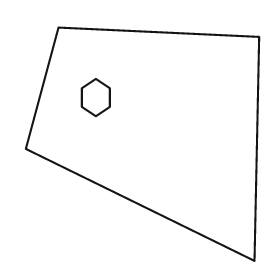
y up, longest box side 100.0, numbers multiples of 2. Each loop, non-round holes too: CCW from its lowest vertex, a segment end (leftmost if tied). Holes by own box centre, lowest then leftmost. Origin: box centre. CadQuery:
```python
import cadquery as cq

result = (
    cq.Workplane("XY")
    .moveTo(48.0, -50.0)
    .lineTo(50.0, 46.0)
    .lineTo(-36.0, 50.0)
    .lineTo(-50.0, -2.0)
    .close()
    .moveTo(-20.0, 12.0)
    .lineTo(-14.0, 16.0)
    .lineTo(-14.0, 24.0)
    .lineTo(-20.0, 28.0)
    .lineTo(-26.0, 24.0)
    .lineTo(-26.0, 16.0)
    .close()
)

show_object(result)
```